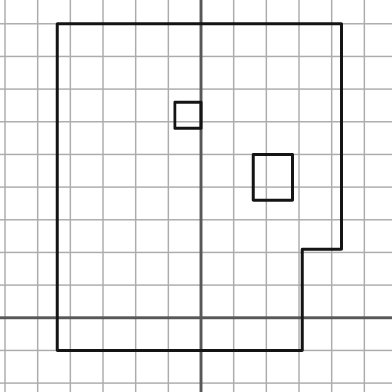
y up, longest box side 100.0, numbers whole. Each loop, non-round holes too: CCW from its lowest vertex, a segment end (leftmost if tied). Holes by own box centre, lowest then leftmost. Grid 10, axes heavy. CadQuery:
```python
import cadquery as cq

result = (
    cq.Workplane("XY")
    .moveTo(-44.0, -10.0)
    .lineTo(31.0, -10.0)
    .lineTo(31.0, 21.0)
    .lineTo(43.0, 21.0)
    .lineTo(43.0, 90.0)
    .lineTo(-44.0, 90.0)
    .close()
    .moveTo(16.0, 36.0)
    .lineTo(28.0, 36.0)
    .lineTo(28.0, 50.0)
    .lineTo(16.0, 50.0)
    .close()
    .moveTo(-8.0, 58.0)
    .lineTo(0.0, 58.0)
    .lineTo(0.0, 66.0)
    .lineTo(-8.0, 66.0)
    .close()
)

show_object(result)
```